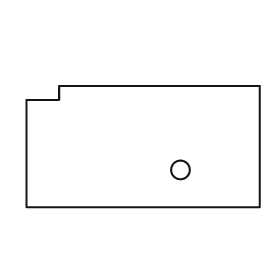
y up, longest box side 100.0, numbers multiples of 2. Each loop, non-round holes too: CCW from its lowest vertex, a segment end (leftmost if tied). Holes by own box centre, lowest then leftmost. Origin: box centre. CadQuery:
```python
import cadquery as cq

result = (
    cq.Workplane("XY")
    .moveTo(-50.0, -26.0)
    .lineTo(50.0, -26.0)
    .lineTo(50.0, 26.0)
    .lineTo(-36.0, 26.0)
    .lineTo(-36.0, 20.0)
    .lineTo(-50.0, 20.0)
    .close()
    .moveTo(16.0, -10.0)
    .circle(4.0)
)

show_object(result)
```